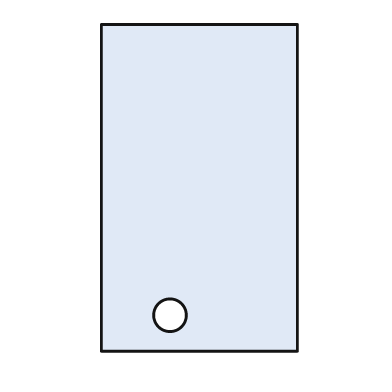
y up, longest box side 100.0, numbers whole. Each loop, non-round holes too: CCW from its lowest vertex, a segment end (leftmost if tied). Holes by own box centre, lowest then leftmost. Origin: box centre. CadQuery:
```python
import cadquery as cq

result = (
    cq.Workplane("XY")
    .moveTo(-30.0, -50.0)
    .lineTo(30.0, -50.0)
    .lineTo(30.0, 50.0)
    .lineTo(-30.0, 50.0)
    .close()
    .moveTo(-9.0, -39.0)
    .circle(5.0)
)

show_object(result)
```